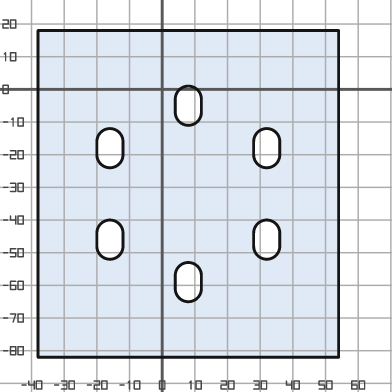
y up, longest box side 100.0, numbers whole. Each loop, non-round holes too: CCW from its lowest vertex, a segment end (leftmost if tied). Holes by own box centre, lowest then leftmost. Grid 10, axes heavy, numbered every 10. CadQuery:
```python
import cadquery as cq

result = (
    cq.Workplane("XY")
    .moveTo(-38.0, -82.0)
    .lineTo(54.0, -82.0)
    .lineTo(54.0, 18.0)
    .lineTo(-38.0, 18.0)
    .close()
    .moveTo(4.0, -61.0)
    .threePointArc((8.0, -65.0), (12.0, -61.0))
    .lineTo(12.0, -57.0)
    .threePointArc((8.0, -53.0), (4.0, -57.0))
    .close()
    .moveTo(-20.0, -48.0)
    .threePointArc((-16.0, -52.0), (-12.0, -48.0))
    .lineTo(-12.0, -44.0)
    .threePointArc((-16.0, -40.0), (-20.0, -44.0))
    .close()
    .moveTo(28.0, -48.0)
    .threePointArc((32.0, -52.0), (36.0, -48.0))
    .lineTo(36.0, -44.0)
    .threePointArc((32.0, -40.0), (28.0, -44.0))
    .close()
    .moveTo(-20.0, -20.0)
    .threePointArc((-16.0, -24.0), (-12.0, -20.0))
    .lineTo(-12.0, -16.0)
    .threePointArc((-16.0, -12.0), (-20.0, -16.0))
    .close()
    .moveTo(28.0, -20.0)
    .threePointArc((32.0, -24.0), (36.0, -20.0))
    .lineTo(36.0, -16.0)
    .threePointArc((32.0, -12.0), (28.0, -16.0))
    .close()
    .moveTo(4.0, -7.0)
    .threePointArc((8.0, -11.0), (12.0, -7.0))
    .lineTo(12.0, -3.0)
    .threePointArc((8.0, 1.0), (4.0, -3.0))
    .close()
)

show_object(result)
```